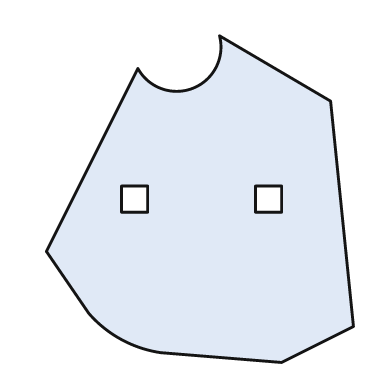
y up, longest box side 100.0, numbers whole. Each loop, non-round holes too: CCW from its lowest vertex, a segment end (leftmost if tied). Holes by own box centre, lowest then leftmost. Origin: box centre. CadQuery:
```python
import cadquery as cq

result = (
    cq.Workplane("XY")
    .moveTo(25.0, -50.0)
    .lineTo(47.0, -39.0)
    .lineTo(40.0, 30.0)
    .lineTo(6.0, 50.0)
    .threePointArc((-2.0, 34.0), (-19.0, 40.0))
    .lineTo(-47.0, -16.0)
    .lineTo(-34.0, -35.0)
    .threePointArc((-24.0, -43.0), (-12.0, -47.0))
    .close()
    .moveTo(-24.0, -4.0)
    .lineTo(-16.0, -4.0)
    .lineTo(-16.0, 4.0)
    .lineTo(-24.0, 4.0)
    .close()
    .moveTo(17.0, -4.0)
    .lineTo(25.0, -4.0)
    .lineTo(25.0, 4.0)
    .lineTo(17.0, 4.0)
    .close()
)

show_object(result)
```